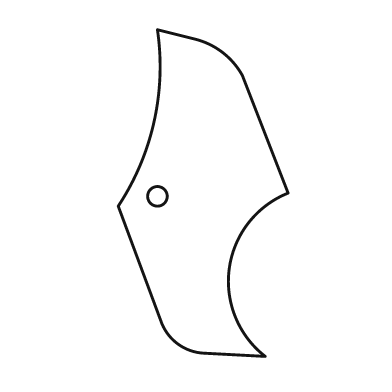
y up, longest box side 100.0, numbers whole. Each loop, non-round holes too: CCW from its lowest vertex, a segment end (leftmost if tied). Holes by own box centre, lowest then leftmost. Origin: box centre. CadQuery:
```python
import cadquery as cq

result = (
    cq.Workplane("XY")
    .moveTo(19.0, -50.0)
    .threePointArc((8.0, -23.0), (26.0, 0.0))
    .lineTo(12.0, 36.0)
    .threePointArc((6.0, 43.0), (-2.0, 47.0))
    .lineTo(-14.0, 50.0)
    .threePointArc((-15.0, 22.0), (-26.0, -4.0))
    .lineTo(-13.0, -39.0)
    .threePointArc((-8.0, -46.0), (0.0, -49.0))
    .close()
    .moveTo(-14.0, -1.0)
    .circle(3.0)
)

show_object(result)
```